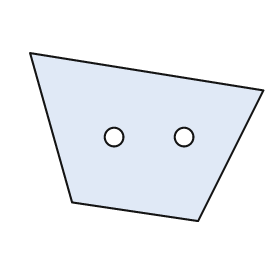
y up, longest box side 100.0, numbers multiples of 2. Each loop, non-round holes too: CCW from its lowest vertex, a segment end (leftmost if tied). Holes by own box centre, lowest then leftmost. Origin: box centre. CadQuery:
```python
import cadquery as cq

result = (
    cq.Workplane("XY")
    .moveTo(22.0, -36.0)
    .lineTo(50.0, 20.0)
    .lineTo(-50.0, 36.0)
    .lineTo(-32.0, -28.0)
    .close()
    .moveTo(-14.0, 0.0)
    .circle(4.0)
    .moveTo(16.0, 0.0)
    .circle(4.0)
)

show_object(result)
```